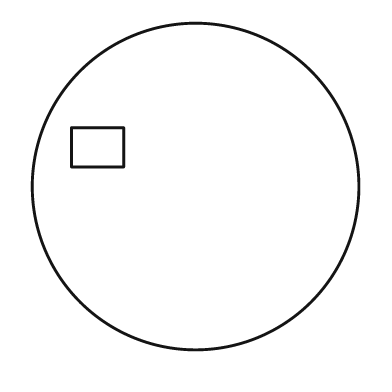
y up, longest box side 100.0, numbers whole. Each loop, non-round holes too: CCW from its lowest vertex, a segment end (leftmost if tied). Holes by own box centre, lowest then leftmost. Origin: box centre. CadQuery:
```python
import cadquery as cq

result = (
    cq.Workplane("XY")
    .moveTo(0.0, 0.0)
    .circle(50.0)
    .moveTo(-38.0, 6.0)
    .lineTo(-22.0, 6.0)
    .lineTo(-22.0, 18.0)
    .lineTo(-38.0, 18.0)
    .close()
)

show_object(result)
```